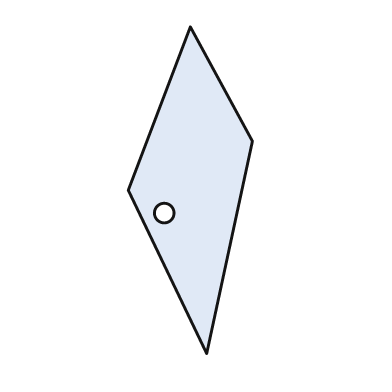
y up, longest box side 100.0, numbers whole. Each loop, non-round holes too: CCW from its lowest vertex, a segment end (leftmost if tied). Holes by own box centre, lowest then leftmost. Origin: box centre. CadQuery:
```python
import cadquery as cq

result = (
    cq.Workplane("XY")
    .moveTo(5.0, -50.0)
    .lineTo(19.0, 15.0)
    .lineTo(0.0, 50.0)
    .lineTo(-19.0, 0.0)
    .close()
    .moveTo(-8.0, -7.0)
    .circle(3.0)
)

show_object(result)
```